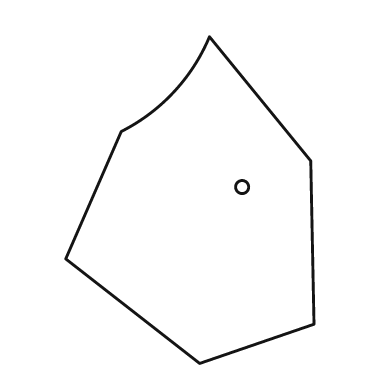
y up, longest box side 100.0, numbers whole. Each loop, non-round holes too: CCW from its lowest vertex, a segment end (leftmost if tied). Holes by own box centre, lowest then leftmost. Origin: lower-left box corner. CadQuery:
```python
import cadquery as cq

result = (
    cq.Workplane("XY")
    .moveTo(41.0, 0.0)
    .lineTo(76.0, 12.0)
    .lineTo(75.0, 62.0)
    .lineTo(44.0, 100.0)
    .threePointArc((33.0, 83.0), (17.0, 71.0))
    .lineTo(0.0, 32.0)
    .close()
    .moveTo(54.0, 54.0)
    .circle(2.0)
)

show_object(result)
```